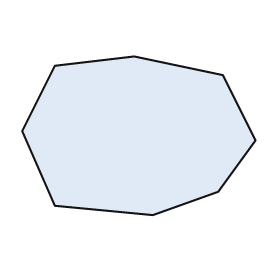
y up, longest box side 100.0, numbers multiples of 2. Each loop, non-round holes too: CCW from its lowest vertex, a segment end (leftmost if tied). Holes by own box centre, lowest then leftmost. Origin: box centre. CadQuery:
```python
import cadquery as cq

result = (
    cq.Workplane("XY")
    .moveTo(6.0, -34.0)
    .lineTo(34.0, -24.0)
    .lineTo(50.0, -2.0)
    .lineTo(36.0, 26.0)
    .lineTo(-2.0, 34.0)
    .lineTo(-36.0, 30.0)
    .lineTo(-50.0, 2.0)
    .lineTo(-36.0, -30.0)
    .close()
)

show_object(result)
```